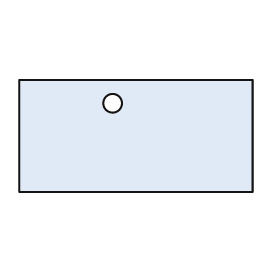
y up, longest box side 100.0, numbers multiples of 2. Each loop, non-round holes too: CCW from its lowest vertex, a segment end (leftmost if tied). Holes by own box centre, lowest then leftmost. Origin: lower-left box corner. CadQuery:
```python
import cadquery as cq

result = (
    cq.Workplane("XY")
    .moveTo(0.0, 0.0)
    .lineTo(100.0, 0.0)
    .lineTo(100.0, 48.0)
    .lineTo(0.0, 48.0)
    .close()
    .moveTo(40.0, 38.0)
    .circle(4.0)
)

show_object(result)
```